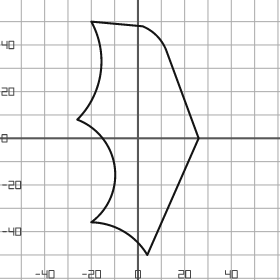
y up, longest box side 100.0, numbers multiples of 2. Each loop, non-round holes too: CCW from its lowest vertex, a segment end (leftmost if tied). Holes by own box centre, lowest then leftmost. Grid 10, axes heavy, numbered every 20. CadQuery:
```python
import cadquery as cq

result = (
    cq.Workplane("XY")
    .moveTo(4.0, -50.0)
    .lineTo(26.0, 0.0)
    .lineTo(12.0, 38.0)
    .threePointArc((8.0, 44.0), (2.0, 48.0))
    .lineTo(-20.0, 50.0)
    .threePointArc((-16.0, 28.0), (-26.0, 8.0))
    .threePointArc((-10.0, -12.0), (-20.0, -36.0))
    .threePointArc((-6.0, -40.0), (4.0, -50.0))
    .close()
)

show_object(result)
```